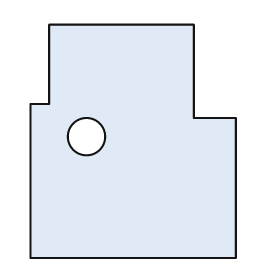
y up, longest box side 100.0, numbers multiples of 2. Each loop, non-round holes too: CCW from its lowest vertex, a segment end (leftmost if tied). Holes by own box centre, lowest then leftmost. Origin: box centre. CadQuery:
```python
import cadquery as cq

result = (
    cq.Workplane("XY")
    .moveTo(-44.0, -50.0)
    .lineTo(44.0, -50.0)
    .lineTo(44.0, 10.0)
    .lineTo(26.0, 10.0)
    .lineTo(26.0, 50.0)
    .lineTo(-36.0, 50.0)
    .lineTo(-36.0, 16.0)
    .lineTo(-44.0, 16.0)
    .close()
    .moveTo(-20.0, 2.0)
    .circle(8.0)
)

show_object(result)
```